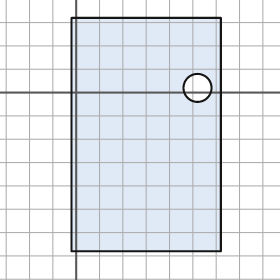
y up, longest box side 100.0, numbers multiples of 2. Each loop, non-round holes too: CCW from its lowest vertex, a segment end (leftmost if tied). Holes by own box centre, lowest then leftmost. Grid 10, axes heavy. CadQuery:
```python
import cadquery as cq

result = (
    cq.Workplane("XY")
    .moveTo(-2.0, -68.0)
    .lineTo(62.0, -68.0)
    .lineTo(62.0, 32.0)
    .lineTo(-2.0, 32.0)
    .close()
    .moveTo(52.0, 2.0)
    .circle(6.0)
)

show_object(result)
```